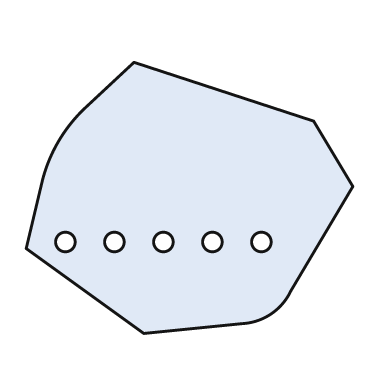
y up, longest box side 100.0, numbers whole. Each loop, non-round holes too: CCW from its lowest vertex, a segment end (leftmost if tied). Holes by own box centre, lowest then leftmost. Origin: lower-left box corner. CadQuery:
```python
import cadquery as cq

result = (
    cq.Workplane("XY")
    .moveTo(36.0, 0.0)
    .lineTo(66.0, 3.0)
    .threePointArc((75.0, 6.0), (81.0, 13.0))
    .lineTo(100.0, 45.0)
    .lineTo(88.0, 65.0)
    .lineTo(33.0, 83.0)
    .lineTo(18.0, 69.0)
    .threePointArc((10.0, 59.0), (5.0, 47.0))
    .lineTo(0.0, 26.0)
    .close()
    .moveTo(12.0, 28.0)
    .circle(3.0)
    .moveTo(27.0, 28.0)
    .circle(3.0)
    .moveTo(42.0, 28.0)
    .circle(3.0)
    .moveTo(57.0, 28.0)
    .circle(3.0)
    .moveTo(72.0, 28.0)
    .circle(3.0)
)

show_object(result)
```